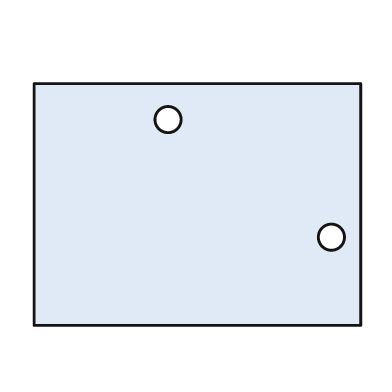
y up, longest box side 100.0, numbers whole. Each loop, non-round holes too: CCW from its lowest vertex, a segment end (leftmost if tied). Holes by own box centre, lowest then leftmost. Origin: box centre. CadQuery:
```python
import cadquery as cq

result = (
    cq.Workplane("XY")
    .moveTo(-50.0, -37.0)
    .lineTo(50.0, -37.0)
    .lineTo(50.0, 37.0)
    .lineTo(-50.0, 37.0)
    .close()
    .moveTo(41.0, -10.0)
    .circle(4.0)
    .moveTo(-9.0, 26.0)
    .circle(4.0)
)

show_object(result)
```